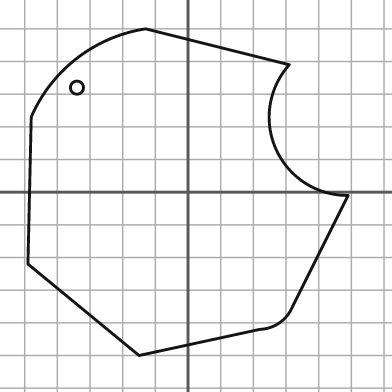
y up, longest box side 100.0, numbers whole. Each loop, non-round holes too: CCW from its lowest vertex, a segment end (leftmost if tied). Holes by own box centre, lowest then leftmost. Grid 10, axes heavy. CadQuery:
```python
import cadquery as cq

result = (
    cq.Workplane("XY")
    .moveTo(-15.0, -50.0)
    .lineTo(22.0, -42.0)
    .threePointArc((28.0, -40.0), (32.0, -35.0))
    .lineTo(49.0, -1.0)
    .threePointArc((27.0, 13.0), (31.0, 39.0))
    .lineTo(-13.0, 50.0)
    .threePointArc((-34.0, 41.0), (-48.0, 23.0))
    .lineTo(-49.0, -22.0)
    .close()
    .moveTo(-34.0, 32.0)
    .circle(2.0)
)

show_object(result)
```